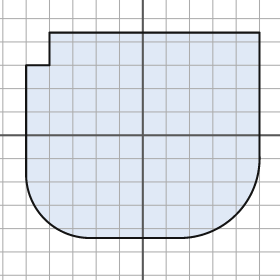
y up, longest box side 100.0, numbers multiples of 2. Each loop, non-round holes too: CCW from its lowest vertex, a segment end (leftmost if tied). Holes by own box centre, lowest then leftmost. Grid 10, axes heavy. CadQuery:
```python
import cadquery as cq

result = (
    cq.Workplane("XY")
    .moveTo(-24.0, -44.0)
    .lineTo(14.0, -44.0)
    .threePointArc((40.0, -34.0), (50.0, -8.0))
    .lineTo(50.0, 44.0)
    .lineTo(-40.0, 44.0)
    .lineTo(-40.0, 30.0)
    .lineTo(-50.0, 30.0)
    .lineTo(-50.0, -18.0)
    .threePointArc((-42.0, -36.0), (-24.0, -44.0))
    .close()
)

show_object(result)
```